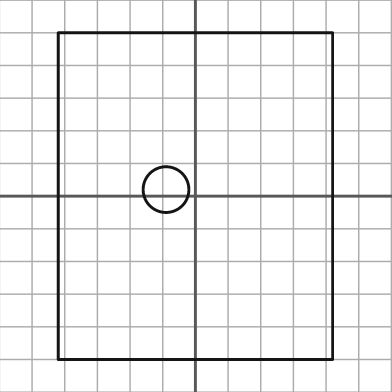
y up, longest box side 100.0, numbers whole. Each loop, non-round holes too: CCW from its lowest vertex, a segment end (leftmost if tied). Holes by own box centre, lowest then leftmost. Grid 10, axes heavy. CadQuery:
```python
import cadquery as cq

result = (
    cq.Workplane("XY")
    .moveTo(-42.0, -50.0)
    .lineTo(42.0, -50.0)
    .lineTo(42.0, 50.0)
    .lineTo(-42.0, 50.0)
    .close()
    .moveTo(-9.0, 2.0)
    .circle(7.0)
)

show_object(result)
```